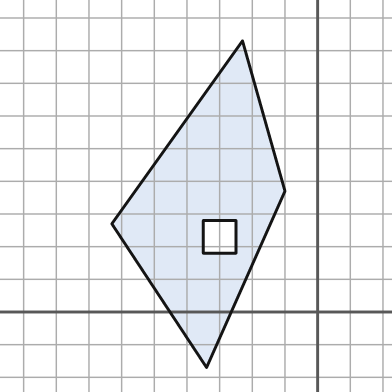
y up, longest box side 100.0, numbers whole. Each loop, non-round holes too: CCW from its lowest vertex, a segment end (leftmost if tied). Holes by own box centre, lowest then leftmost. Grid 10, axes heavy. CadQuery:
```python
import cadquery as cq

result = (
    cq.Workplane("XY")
    .moveTo(-34.0, -17.0)
    .lineTo(-10.0, 37.0)
    .lineTo(-23.0, 83.0)
    .lineTo(-63.0, 27.0)
    .close()
    .moveTo(-35.0, 18.0)
    .lineTo(-25.0, 18.0)
    .lineTo(-25.0, 28.0)
    .lineTo(-35.0, 28.0)
    .close()
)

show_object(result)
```